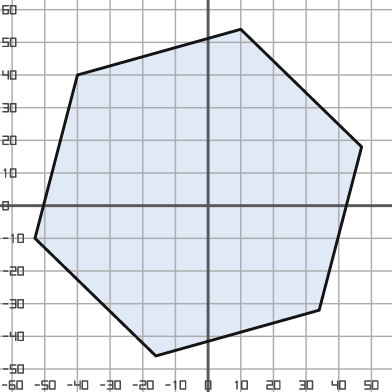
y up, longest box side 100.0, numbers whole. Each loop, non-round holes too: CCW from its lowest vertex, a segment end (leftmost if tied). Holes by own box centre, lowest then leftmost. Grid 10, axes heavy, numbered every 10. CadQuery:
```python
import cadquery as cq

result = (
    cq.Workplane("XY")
    .moveTo(-16.0, -46.0)
    .lineTo(34.0, -32.0)
    .lineTo(47.0, 18.0)
    .lineTo(10.0, 54.0)
    .lineTo(-40.0, 40.0)
    .lineTo(-53.0, -10.0)
    .close()
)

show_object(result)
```